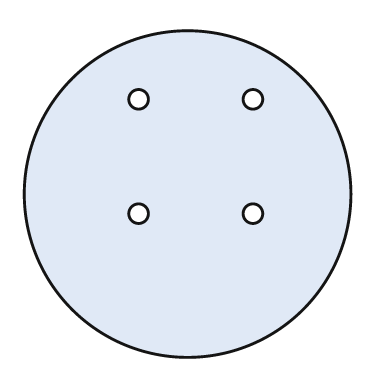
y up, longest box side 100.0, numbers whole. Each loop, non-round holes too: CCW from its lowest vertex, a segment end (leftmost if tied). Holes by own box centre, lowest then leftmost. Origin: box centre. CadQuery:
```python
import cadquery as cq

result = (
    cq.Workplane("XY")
    .moveTo(0.0, 0.0)
    .circle(50.0)
    .moveTo(-15.0, -6.0)
    .circle(3.0)
    .moveTo(20.0, -6.0)
    .circle(3.0)
    .moveTo(-15.0, 29.0)
    .circle(3.0)
    .moveTo(20.0, 29.0)
    .circle(3.0)
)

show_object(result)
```